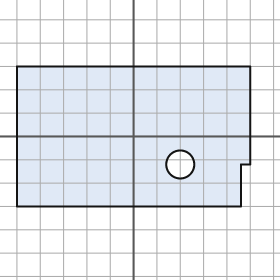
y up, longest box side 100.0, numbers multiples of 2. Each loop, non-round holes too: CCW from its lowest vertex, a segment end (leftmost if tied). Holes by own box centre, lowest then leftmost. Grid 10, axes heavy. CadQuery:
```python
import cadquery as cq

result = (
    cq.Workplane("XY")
    .moveTo(-50.0, -30.0)
    .lineTo(46.0, -30.0)
    .lineTo(46.0, -12.0)
    .lineTo(50.0, -12.0)
    .lineTo(50.0, 30.0)
    .lineTo(-50.0, 30.0)
    .close()
    .moveTo(20.0, -12.0)
    .circle(6.0)
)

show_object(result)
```